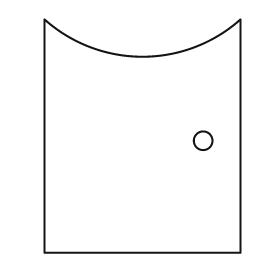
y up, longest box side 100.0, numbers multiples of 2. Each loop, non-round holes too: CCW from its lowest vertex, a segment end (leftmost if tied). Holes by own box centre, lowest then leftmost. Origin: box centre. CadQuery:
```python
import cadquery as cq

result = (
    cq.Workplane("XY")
    .moveTo(-42.0, -50.0)
    .lineTo(42.0, -50.0)
    .lineTo(42.0, 50.0)
    .threePointArc((0.0, 34.0), (-42.0, 50.0))
    .close()
    .moveTo(26.0, -2.0)
    .circle(4.0)
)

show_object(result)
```